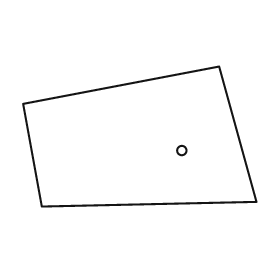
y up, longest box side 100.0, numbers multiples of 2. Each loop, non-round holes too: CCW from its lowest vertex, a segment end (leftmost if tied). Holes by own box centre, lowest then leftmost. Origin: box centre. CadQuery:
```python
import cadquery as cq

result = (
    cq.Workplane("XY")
    .moveTo(-42.0, -30.0)
    .lineTo(50.0, -28.0)
    .lineTo(34.0, 30.0)
    .lineTo(-50.0, 14.0)
    .close()
    .moveTo(18.0, -6.0)
    .circle(2.0)
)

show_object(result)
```